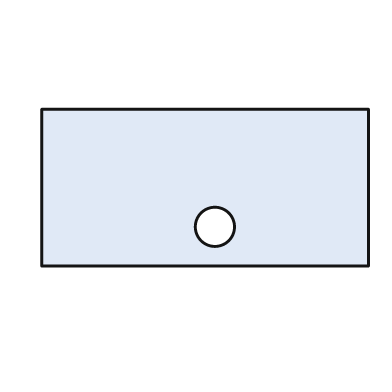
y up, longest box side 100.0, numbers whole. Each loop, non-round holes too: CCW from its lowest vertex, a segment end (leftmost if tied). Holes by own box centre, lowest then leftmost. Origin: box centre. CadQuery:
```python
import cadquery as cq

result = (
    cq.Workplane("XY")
    .moveTo(-50.0, -24.0)
    .lineTo(50.0, -24.0)
    .lineTo(50.0, 24.0)
    .lineTo(-50.0, 24.0)
    .close()
    .moveTo(3.0, -12.0)
    .circle(6.0)
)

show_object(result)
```